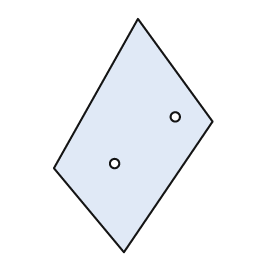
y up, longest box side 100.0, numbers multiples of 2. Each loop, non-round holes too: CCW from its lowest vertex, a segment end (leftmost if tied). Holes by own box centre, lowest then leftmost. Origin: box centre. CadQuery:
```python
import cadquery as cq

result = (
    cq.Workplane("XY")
    .moveTo(-4.0, -50.0)
    .lineTo(34.0, 6.0)
    .lineTo(2.0, 50.0)
    .lineTo(-34.0, -14.0)
    .close()
    .moveTo(-8.0, -12.0)
    .circle(2.0)
    .moveTo(18.0, 8.0)
    .circle(2.0)
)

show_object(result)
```